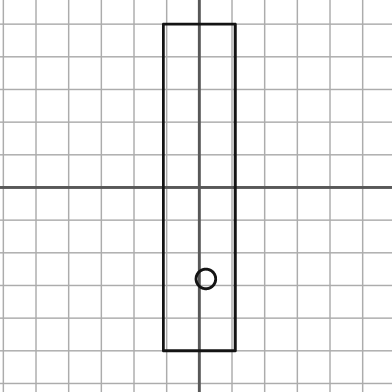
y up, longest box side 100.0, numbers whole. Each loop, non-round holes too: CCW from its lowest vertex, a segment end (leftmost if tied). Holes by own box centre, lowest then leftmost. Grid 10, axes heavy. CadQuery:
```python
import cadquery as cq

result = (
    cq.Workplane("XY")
    .moveTo(-11.0, -50.0)
    .lineTo(11.0, -50.0)
    .lineTo(11.0, 50.0)
    .lineTo(-11.0, 50.0)
    .close()
    .moveTo(2.0, -28.0)
    .circle(3.0)
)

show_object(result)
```